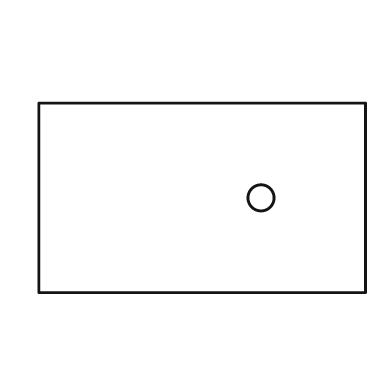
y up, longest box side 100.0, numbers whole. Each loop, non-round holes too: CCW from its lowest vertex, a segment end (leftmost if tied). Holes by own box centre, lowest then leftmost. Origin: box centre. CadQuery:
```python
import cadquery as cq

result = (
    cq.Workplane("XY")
    .moveTo(-50.0, -29.0)
    .lineTo(50.0, -29.0)
    .lineTo(50.0, 29.0)
    .lineTo(-50.0, 29.0)
    .close()
    .moveTo(18.0, 0.0)
    .circle(4.0)
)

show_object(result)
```